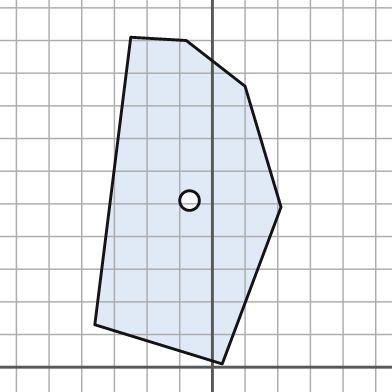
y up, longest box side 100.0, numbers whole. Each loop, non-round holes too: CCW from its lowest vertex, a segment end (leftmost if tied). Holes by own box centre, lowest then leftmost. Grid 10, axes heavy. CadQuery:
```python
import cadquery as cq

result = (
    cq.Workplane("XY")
    .moveTo(3.0, 1.0)
    .lineTo(21.0, 49.0)
    .lineTo(10.0, 86.0)
    .lineTo(-8.0, 100.0)
    .lineTo(-25.0, 101.0)
    .lineTo(-36.0, 13.0)
    .close()
    .moveTo(-7.0, 51.0)
    .circle(3.0)
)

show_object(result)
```